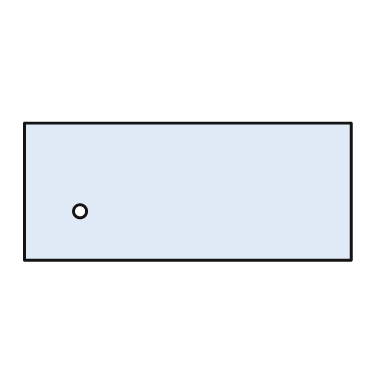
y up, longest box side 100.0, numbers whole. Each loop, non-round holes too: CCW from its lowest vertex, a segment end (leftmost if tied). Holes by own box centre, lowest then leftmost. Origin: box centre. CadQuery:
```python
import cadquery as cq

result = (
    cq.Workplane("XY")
    .moveTo(-50.0, -21.0)
    .lineTo(50.0, -21.0)
    .lineTo(50.0, 21.0)
    .lineTo(-50.0, 21.0)
    .close()
    .moveTo(-33.0, -6.0)
    .circle(2.0)
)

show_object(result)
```